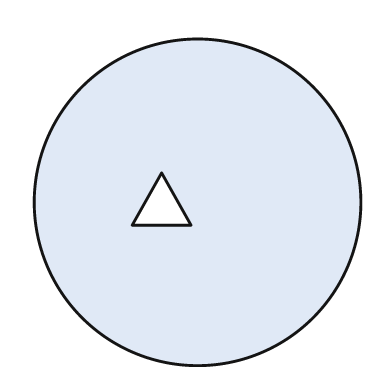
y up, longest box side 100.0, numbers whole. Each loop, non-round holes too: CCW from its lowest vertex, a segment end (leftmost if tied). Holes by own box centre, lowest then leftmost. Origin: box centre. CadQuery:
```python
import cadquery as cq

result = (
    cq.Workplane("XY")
    .moveTo(0.0, 0.0)
    .circle(50.0)
    .moveTo(-20.0, -7.0)
    .lineTo(-2.0, -7.0)
    .lineTo(-11.0, 9.0)
    .close()
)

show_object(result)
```